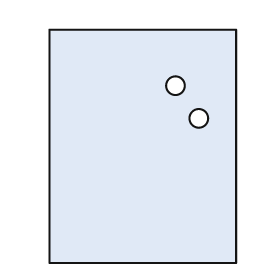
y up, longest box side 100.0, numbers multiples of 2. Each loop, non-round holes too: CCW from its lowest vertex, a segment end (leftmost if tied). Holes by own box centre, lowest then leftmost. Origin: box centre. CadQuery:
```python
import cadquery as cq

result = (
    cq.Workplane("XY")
    .moveTo(-40.0, -50.0)
    .lineTo(40.0, -50.0)
    .lineTo(40.0, 50.0)
    .lineTo(-40.0, 50.0)
    .close()
    .moveTo(24.0, 12.0)
    .circle(4.0)
    .moveTo(14.0, 26.0)
    .circle(4.0)
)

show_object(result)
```